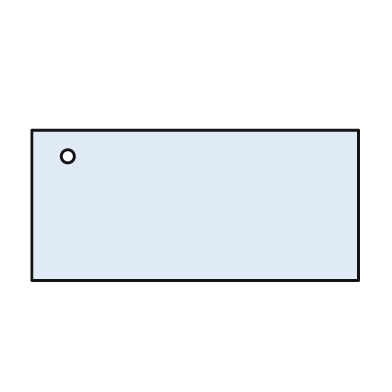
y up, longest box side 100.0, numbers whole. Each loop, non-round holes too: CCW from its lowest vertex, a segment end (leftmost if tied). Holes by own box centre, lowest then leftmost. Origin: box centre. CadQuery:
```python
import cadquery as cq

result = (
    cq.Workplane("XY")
    .moveTo(-50.0, -23.0)
    .lineTo(50.0, -23.0)
    .lineTo(50.0, 23.0)
    .lineTo(-50.0, 23.0)
    .close()
    .moveTo(-39.0, 15.0)
    .circle(2.0)
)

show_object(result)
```